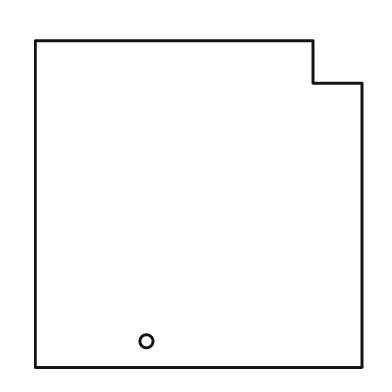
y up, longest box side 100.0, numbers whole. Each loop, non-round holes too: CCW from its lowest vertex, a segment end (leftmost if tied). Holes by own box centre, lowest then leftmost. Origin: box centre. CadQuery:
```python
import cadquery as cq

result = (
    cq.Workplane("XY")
    .moveTo(-50.0, -50.0)
    .lineTo(50.0, -50.0)
    .lineTo(50.0, 37.0)
    .lineTo(35.0, 37.0)
    .lineTo(35.0, 50.0)
    .lineTo(-50.0, 50.0)
    .close()
    .moveTo(-16.0, -42.0)
    .circle(2.0)
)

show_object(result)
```